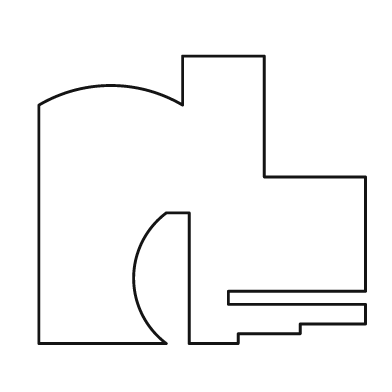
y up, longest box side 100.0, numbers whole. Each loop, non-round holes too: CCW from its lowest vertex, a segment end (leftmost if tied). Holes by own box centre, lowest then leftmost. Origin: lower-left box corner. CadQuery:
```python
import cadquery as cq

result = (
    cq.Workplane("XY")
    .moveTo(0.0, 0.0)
    .lineTo(39.0, 0.0)
    .threePointArc((29.0, 20.0), (39.0, 40.0))
    .lineTo(46.0, 40.0)
    .lineTo(46.0, 0.0)
    .lineTo(61.0, 0.0)
    .lineTo(61.0, 3.0)
    .lineTo(80.0, 3.0)
    .lineTo(80.0, 6.0)
    .lineTo(100.0, 6.0)
    .lineTo(100.0, 12.0)
    .lineTo(58.0, 12.0)
    .lineTo(58.0, 16.0)
    .lineTo(100.0, 16.0)
    .lineTo(100.0, 51.0)
    .lineTo(69.0, 51.0)
    .lineTo(69.0, 88.0)
    .lineTo(44.0, 88.0)
    .lineTo(44.0, 73.0)
    .threePointArc((22.0, 79.0), (0.0, 73.0))
    .close()
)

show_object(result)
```